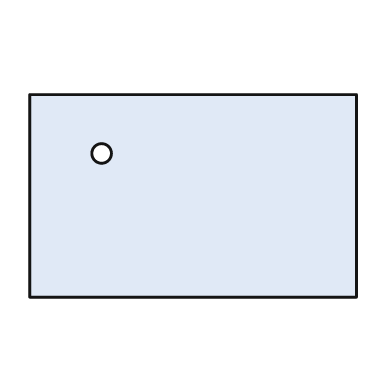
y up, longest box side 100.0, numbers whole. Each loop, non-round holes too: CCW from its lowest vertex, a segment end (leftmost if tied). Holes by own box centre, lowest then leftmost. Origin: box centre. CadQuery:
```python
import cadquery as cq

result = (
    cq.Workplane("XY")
    .moveTo(-50.0, -31.0)
    .lineTo(50.0, -31.0)
    .lineTo(50.0, 31.0)
    .lineTo(-50.0, 31.0)
    .close()
    .moveTo(-28.0, 13.0)
    .circle(3.0)
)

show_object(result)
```